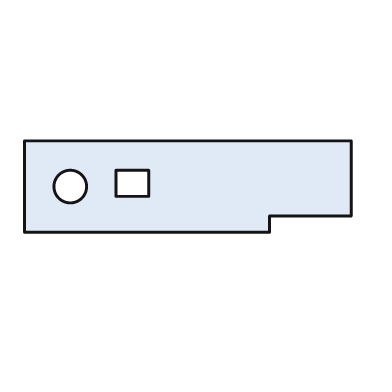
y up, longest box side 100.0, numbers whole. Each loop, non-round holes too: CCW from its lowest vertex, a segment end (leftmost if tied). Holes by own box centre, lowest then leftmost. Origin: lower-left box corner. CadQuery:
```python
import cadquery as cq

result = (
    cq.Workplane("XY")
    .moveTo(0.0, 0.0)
    .lineTo(75.0, 0.0)
    .lineTo(75.0, 5.0)
    .lineTo(100.0, 5.0)
    .lineTo(100.0, 28.0)
    .lineTo(0.0, 28.0)
    .close()
    .moveTo(14.0, 14.0)
    .circle(5.0)
    .moveTo(28.0, 11.0)
    .lineTo(38.0, 11.0)
    .lineTo(38.0, 19.0)
    .lineTo(28.0, 19.0)
    .close()
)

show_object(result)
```